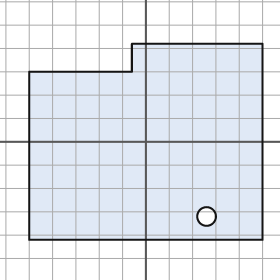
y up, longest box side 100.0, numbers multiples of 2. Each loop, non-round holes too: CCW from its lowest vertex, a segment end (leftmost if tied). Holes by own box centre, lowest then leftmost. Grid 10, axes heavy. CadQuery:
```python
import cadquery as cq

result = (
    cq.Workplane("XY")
    .moveTo(-50.0, -42.0)
    .lineTo(50.0, -42.0)
    .lineTo(50.0, 42.0)
    .lineTo(-6.0, 42.0)
    .lineTo(-6.0, 30.0)
    .lineTo(-50.0, 30.0)
    .close()
    .moveTo(26.0, -32.0)
    .circle(4.0)
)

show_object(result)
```